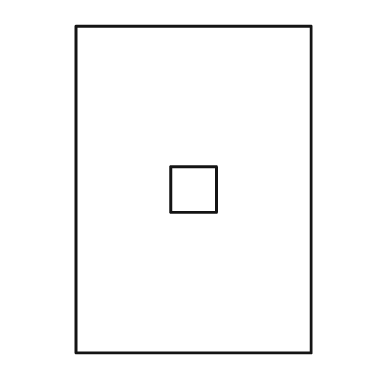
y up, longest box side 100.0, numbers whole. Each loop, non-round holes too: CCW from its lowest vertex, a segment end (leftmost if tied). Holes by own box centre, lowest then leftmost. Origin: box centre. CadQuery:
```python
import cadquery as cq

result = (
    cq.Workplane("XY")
    .moveTo(-36.0, -50.0)
    .lineTo(36.0, -50.0)
    .lineTo(36.0, 50.0)
    .lineTo(-36.0, 50.0)
    .close()
    .moveTo(-7.0, -7.0)
    .lineTo(7.0, -7.0)
    .lineTo(7.0, 7.0)
    .lineTo(-7.0, 7.0)
    .close()
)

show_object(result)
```